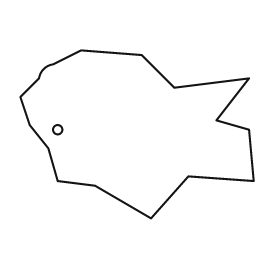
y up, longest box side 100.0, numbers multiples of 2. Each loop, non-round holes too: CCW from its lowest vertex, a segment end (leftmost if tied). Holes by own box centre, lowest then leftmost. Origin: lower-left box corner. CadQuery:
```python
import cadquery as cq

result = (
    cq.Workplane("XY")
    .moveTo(56.0, 0.0)
    .lineTo(72.0, 18.0)
    .lineTo(100.0, 16.0)
    .lineTo(98.0, 38.0)
    .lineTo(84.0, 42.0)
    .lineTo(98.0, 60.0)
    .lineTo(66.0, 56.0)
    .lineTo(52.0, 70.0)
    .lineTo(26.0, 72.0)
    .lineTo(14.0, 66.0)
    .threePointArc((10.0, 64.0), (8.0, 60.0))
    .lineTo(0.0, 52.0)
    .lineTo(4.0, 40.0)
    .lineTo(12.0, 30.0)
    .lineTo(16.0, 16.0)
    .lineTo(32.0, 14.0)
    .close()
    .moveTo(16.0, 38.0)
    .circle(2.0)
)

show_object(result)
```